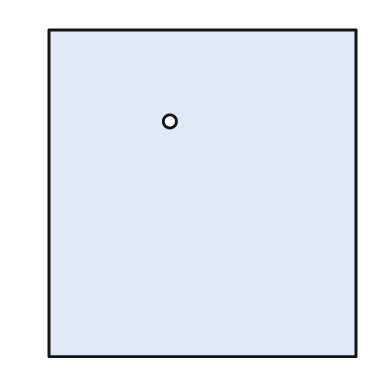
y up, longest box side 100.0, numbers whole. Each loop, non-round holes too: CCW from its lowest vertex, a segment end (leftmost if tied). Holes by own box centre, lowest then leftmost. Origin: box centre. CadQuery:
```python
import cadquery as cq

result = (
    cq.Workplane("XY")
    .moveTo(-47.0, -50.0)
    .lineTo(47.0, -50.0)
    .lineTo(47.0, 50.0)
    .lineTo(-47.0, 50.0)
    .close()
    .moveTo(-10.0, 22.0)
    .circle(2.0)
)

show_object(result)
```